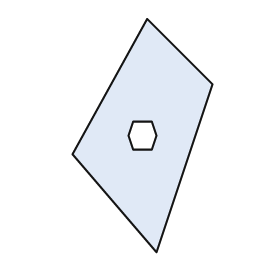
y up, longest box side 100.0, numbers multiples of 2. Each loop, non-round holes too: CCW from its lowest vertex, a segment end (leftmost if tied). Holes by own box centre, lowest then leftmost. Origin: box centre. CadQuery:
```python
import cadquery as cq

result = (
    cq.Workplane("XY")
    .moveTo(6.0, -50.0)
    .lineTo(30.0, 22.0)
    .lineTo(2.0, 50.0)
    .lineTo(-30.0, -8.0)
    .close()
    .moveTo(-4.0, -6.0)
    .lineTo(4.0, -6.0)
    .lineTo(6.0, 0.0)
    .lineTo(4.0, 6.0)
    .lineTo(-4.0, 6.0)
    .lineTo(-6.0, 0.0)
    .close()
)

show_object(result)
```